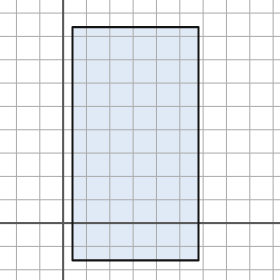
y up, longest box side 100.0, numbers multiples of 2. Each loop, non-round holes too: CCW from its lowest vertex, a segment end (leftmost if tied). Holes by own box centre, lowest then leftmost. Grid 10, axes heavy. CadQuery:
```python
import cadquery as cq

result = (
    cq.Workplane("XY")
    .moveTo(4.0, -16.0)
    .lineTo(58.0, -16.0)
    .lineTo(58.0, 84.0)
    .lineTo(4.0, 84.0)
    .close()
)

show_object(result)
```